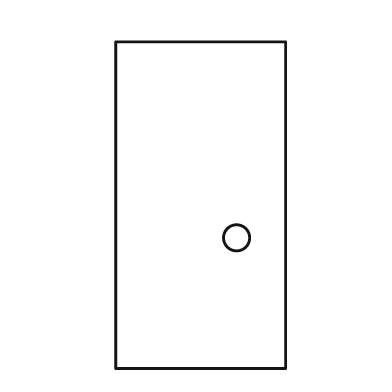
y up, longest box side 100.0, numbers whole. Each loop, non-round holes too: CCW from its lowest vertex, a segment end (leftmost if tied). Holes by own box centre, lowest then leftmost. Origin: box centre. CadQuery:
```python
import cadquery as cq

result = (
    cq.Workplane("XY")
    .moveTo(-26.0, -50.0)
    .lineTo(26.0, -50.0)
    .lineTo(26.0, 50.0)
    .lineTo(-26.0, 50.0)
    .close()
    .moveTo(11.0, -10.0)
    .circle(4.0)
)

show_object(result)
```